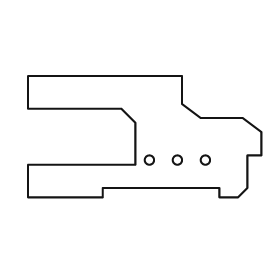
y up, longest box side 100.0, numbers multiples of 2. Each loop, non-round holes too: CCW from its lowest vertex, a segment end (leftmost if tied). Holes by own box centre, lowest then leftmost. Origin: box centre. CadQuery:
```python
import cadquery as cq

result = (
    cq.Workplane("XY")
    .moveTo(-50.0, -26.0)
    .lineTo(-18.0, -26.0)
    .lineTo(-18.0, -22.0)
    .lineTo(32.0, -22.0)
    .lineTo(32.0, -26.0)
    .lineTo(40.0, -26.0)
    .lineTo(44.0, -22.0)
    .lineTo(44.0, -8.0)
    .lineTo(50.0, -8.0)
    .lineTo(50.0, 2.0)
    .lineTo(42.0, 8.0)
    .lineTo(24.0, 8.0)
    .lineTo(16.0, 14.0)
    .lineTo(16.0, 26.0)
    .lineTo(-50.0, 26.0)
    .lineTo(-50.0, 12.0)
    .lineTo(-10.0, 12.0)
    .lineTo(-4.0, 6.0)
    .lineTo(-4.0, -12.0)
    .lineTo(-50.0, -12.0)
    .close()
    .moveTo(2.0, -10.0)
    .circle(2.0)
    .moveTo(14.0, -10.0)
    .circle(2.0)
    .moveTo(26.0, -10.0)
    .circle(2.0)
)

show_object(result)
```